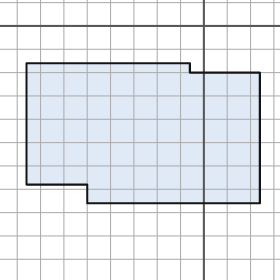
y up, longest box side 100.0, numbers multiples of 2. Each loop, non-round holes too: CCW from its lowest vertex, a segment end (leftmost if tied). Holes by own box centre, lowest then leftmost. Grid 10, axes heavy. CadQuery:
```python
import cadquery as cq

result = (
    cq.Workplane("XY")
    .moveTo(-50.0, -76.0)
    .lineTo(24.0, -76.0)
    .lineTo(24.0, -20.0)
    .lineTo(-6.0, -20.0)
    .lineTo(-6.0, -16.0)
    .lineTo(-76.0, -16.0)
    .lineTo(-76.0, -68.0)
    .lineTo(-50.0, -68.0)
    .close()
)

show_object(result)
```